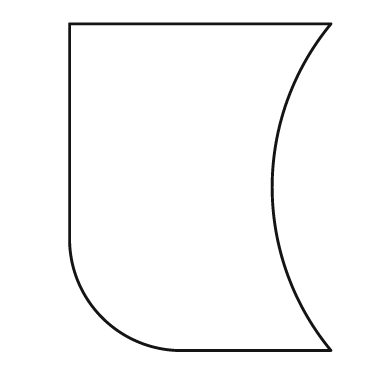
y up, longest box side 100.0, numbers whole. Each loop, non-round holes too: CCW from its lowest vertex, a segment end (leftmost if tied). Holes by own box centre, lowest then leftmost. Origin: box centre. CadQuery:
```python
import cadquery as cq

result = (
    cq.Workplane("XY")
    .moveTo(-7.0, -50.0)
    .lineTo(40.0, -50.0)
    .threePointArc((22.0, 0.0), (40.0, 50.0))
    .lineTo(-40.0, 50.0)
    .lineTo(-40.0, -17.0)
    .threePointArc((-30.0, -40.0), (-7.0, -50.0))
    .close()
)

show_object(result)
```